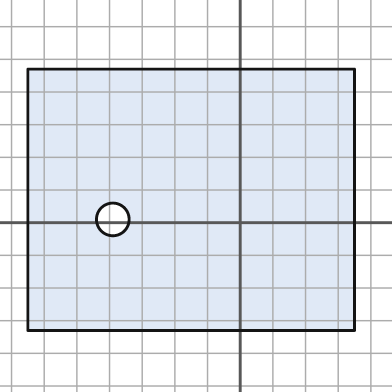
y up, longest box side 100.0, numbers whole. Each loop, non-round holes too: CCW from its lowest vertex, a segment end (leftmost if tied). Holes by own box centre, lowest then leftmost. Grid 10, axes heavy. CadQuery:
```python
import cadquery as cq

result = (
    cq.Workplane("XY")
    .moveTo(-65.0, -33.0)
    .lineTo(35.0, -33.0)
    .lineTo(35.0, 47.0)
    .lineTo(-65.0, 47.0)
    .close()
    .moveTo(-39.0, 1.0)
    .circle(5.0)
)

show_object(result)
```